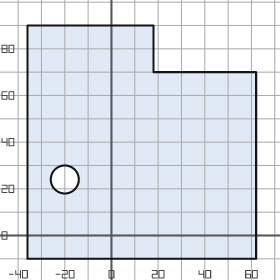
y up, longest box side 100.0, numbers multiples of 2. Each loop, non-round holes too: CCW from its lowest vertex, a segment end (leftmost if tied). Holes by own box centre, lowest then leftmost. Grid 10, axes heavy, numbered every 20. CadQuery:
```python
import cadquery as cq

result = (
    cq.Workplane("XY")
    .moveTo(-36.0, -10.0)
    .lineTo(62.0, -10.0)
    .lineTo(62.0, 70.0)
    .lineTo(18.0, 70.0)
    .lineTo(18.0, 90.0)
    .lineTo(-36.0, 90.0)
    .close()
    .moveTo(-20.0, 24.0)
    .circle(6.0)
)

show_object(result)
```